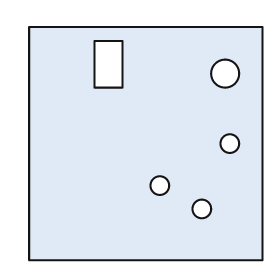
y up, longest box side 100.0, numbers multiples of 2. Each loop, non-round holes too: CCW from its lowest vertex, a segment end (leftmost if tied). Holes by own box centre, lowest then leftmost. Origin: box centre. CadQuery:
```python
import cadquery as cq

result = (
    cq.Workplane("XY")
    .moveTo(-50.0, -50.0)
    .lineTo(50.0, -50.0)
    .lineTo(50.0, 50.0)
    .lineTo(-50.0, 50.0)
    .close()
    .moveTo(24.0, -28.0)
    .circle(4.0)
    .moveTo(6.0, -18.0)
    .circle(4.0)
    .moveTo(36.0, 0.0)
    .circle(4.0)
    .moveTo(34.0, 30.0)
    .circle(6.0)
    .moveTo(-22.0, 24.0)
    .lineTo(-10.0, 24.0)
    .lineTo(-10.0, 44.0)
    .lineTo(-22.0, 44.0)
    .close()
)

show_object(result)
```